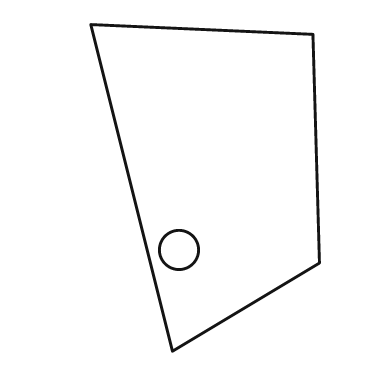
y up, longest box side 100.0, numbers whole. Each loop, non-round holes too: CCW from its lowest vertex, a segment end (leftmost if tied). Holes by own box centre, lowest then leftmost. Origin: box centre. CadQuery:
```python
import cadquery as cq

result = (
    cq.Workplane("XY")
    .moveTo(-10.0, -50.0)
    .lineTo(35.0, -23.0)
    .lineTo(33.0, 47.0)
    .lineTo(-35.0, 50.0)
    .close()
    .moveTo(-8.0, -19.0)
    .circle(6.0)
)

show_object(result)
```